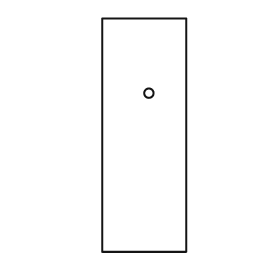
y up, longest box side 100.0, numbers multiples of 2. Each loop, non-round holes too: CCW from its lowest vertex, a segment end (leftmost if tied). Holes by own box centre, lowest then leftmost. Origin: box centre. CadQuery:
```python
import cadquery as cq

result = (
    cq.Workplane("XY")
    .moveTo(-18.0, -50.0)
    .lineTo(18.0, -50.0)
    .lineTo(18.0, 50.0)
    .lineTo(-18.0, 50.0)
    .close()
    .moveTo(2.0, 18.0)
    .circle(2.0)
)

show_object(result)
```